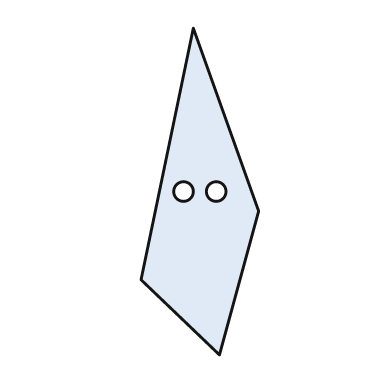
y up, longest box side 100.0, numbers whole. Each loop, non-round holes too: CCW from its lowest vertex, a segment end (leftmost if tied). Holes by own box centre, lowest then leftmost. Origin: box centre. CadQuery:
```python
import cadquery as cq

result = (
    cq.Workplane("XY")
    .moveTo(6.0, -50.0)
    .lineTo(18.0, -6.0)
    .lineTo(-2.0, 50.0)
    .lineTo(-18.0, -27.0)
    .close()
    .moveTo(-5.0, 0.0)
    .circle(3.0)
    .moveTo(5.0, 0.0)
    .circle(3.0)
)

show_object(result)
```